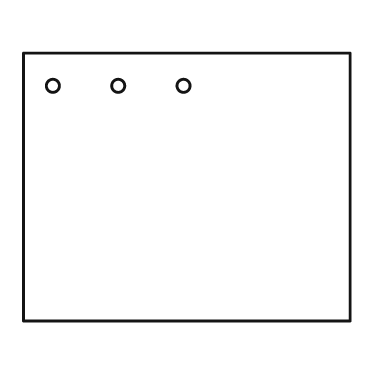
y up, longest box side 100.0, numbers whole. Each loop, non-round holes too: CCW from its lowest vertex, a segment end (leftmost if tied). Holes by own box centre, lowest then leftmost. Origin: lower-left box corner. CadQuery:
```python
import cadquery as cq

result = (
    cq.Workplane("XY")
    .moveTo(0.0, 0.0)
    .lineTo(100.0, 0.0)
    .lineTo(100.0, 82.0)
    .lineTo(0.0, 82.0)
    .close()
    .moveTo(9.0, 72.0)
    .circle(2.0)
    .moveTo(29.0, 72.0)
    .circle(2.0)
    .moveTo(49.0, 72.0)
    .circle(2.0)
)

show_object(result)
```